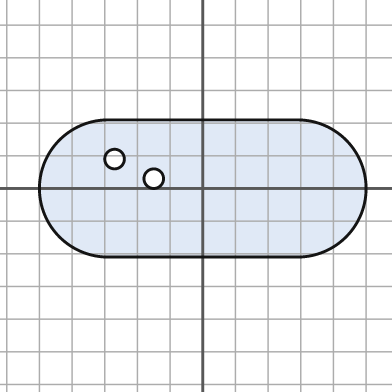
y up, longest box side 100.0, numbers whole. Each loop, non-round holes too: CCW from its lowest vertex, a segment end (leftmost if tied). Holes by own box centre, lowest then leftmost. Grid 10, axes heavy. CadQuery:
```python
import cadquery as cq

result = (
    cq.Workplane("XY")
    .moveTo(-29.0, -21.0)
    .lineTo(29.0, -21.0)
    .threePointArc((50.0, 0.0), (29.0, 21.0))
    .lineTo(-29.0, 21.0)
    .threePointArc((-50.0, 0.0), (-29.0, -21.0))
    .close()
    .moveTo(-15.0, 3.0)
    .circle(3.0)
    .moveTo(-27.0, 9.0)
    .circle(3.0)
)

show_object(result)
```